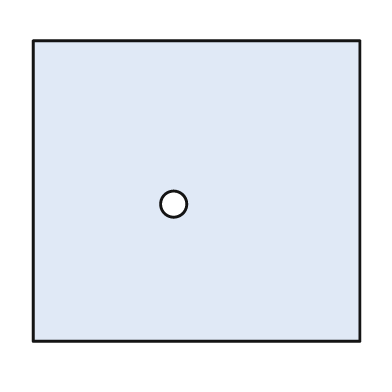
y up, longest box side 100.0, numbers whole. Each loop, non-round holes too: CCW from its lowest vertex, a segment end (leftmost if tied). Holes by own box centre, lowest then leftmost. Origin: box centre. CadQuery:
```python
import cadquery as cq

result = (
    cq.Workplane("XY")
    .moveTo(-50.0, -46.0)
    .lineTo(50.0, -46.0)
    .lineTo(50.0, 46.0)
    .lineTo(-50.0, 46.0)
    .close()
    .moveTo(-7.0, -4.0)
    .circle(4.0)
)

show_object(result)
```